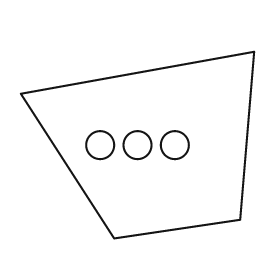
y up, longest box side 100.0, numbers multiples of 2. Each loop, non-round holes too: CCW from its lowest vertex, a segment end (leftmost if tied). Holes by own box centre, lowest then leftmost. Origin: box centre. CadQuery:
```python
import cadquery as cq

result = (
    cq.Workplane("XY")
    .moveTo(-10.0, -40.0)
    .lineTo(44.0, -32.0)
    .lineTo(50.0, 40.0)
    .lineTo(-50.0, 22.0)
    .close()
    .moveTo(-16.0, 0.0)
    .circle(6.0)
    .moveTo(0.0, 0.0)
    .circle(6.0)
    .moveTo(16.0, 0.0)
    .circle(6.0)
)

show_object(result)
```